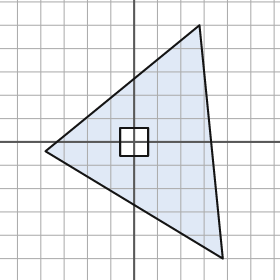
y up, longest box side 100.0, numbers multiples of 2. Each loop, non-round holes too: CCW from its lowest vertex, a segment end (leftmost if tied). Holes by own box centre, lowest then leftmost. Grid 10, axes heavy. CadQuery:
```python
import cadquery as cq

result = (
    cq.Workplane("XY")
    .moveTo(38.0, -50.0)
    .lineTo(28.0, 50.0)
    .lineTo(-38.0, -4.0)
    .close()
    .moveTo(-6.0, -6.0)
    .lineTo(6.0, -6.0)
    .lineTo(6.0, 6.0)
    .lineTo(-6.0, 6.0)
    .close()
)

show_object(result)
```